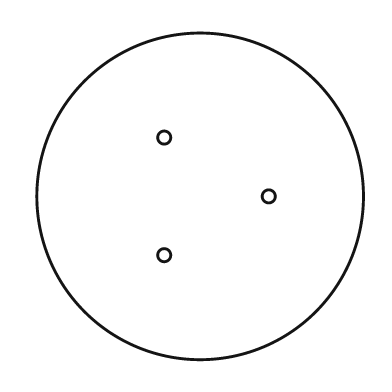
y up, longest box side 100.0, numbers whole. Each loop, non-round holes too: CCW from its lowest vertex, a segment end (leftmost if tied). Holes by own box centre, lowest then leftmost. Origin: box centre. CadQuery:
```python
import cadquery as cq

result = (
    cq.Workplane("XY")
    .moveTo(0.0, 0.0)
    .circle(50.0)
    .moveTo(-11.0, -18.0)
    .circle(2.0)
    .moveTo(21.0, 0.0)
    .circle(2.0)
    .moveTo(-11.0, 18.0)
    .circle(2.0)
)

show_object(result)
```